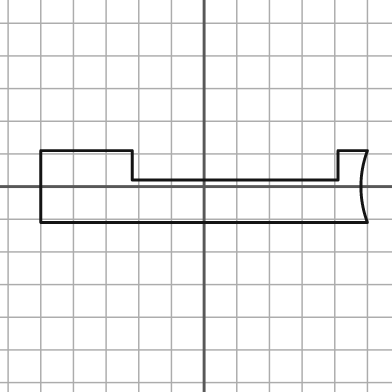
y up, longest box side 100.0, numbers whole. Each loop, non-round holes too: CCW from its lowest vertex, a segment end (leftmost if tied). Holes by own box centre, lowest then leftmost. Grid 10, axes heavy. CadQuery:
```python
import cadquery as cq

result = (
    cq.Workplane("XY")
    .moveTo(-50.0, -11.0)
    .lineTo(50.0, -11.0)
    .threePointArc((48.0, 0.0), (50.0, 11.0))
    .lineTo(41.0, 11.0)
    .lineTo(41.0, 2.0)
    .lineTo(-22.0, 2.0)
    .lineTo(-22.0, 11.0)
    .lineTo(-50.0, 11.0)
    .close()
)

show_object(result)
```